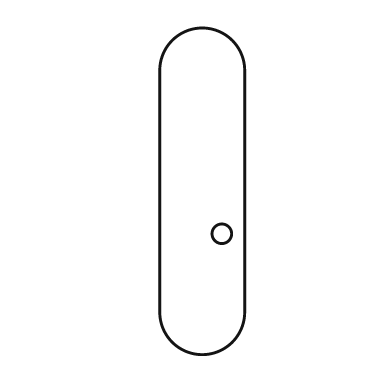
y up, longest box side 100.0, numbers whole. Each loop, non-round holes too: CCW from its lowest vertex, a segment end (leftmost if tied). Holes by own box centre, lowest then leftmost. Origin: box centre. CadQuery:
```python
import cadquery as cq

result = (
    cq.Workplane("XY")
    .moveTo(-13.0, -37.0)
    .threePointArc((0.0, -50.0), (13.0, -37.0))
    .lineTo(13.0, 37.0)
    .threePointArc((0.0, 50.0), (-13.0, 37.0))
    .close()
    .moveTo(6.0, -13.0)
    .circle(3.0)
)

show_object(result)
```